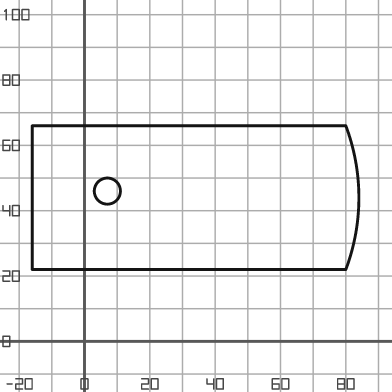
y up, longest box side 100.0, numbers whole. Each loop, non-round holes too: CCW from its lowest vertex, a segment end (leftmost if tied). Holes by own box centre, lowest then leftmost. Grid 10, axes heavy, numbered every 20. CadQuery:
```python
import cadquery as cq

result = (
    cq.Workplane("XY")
    .moveTo(-16.0, 22.0)
    .lineTo(80.0, 22.0)
    .threePointArc((84.0, 44.0), (80.0, 66.0))
    .lineTo(-16.0, 66.0)
    .close()
    .moveTo(7.0, 46.0)
    .circle(4.0)
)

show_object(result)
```